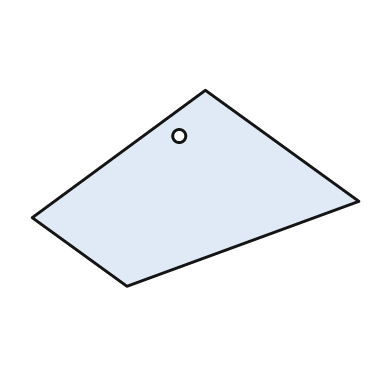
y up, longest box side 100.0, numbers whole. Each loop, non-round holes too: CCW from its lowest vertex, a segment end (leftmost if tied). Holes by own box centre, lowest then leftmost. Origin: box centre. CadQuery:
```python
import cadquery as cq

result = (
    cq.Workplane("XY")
    .moveTo(-21.0, -30.0)
    .lineTo(50.0, -4.0)
    .lineTo(3.0, 30.0)
    .lineTo(-50.0, -9.0)
    .close()
    .moveTo(-5.0, 16.0)
    .circle(2.0)
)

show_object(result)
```